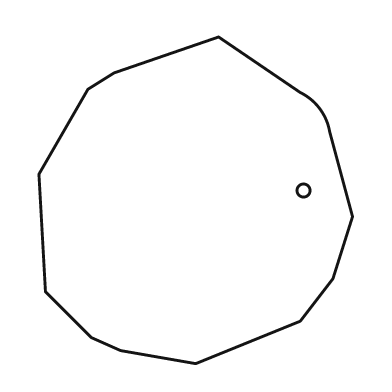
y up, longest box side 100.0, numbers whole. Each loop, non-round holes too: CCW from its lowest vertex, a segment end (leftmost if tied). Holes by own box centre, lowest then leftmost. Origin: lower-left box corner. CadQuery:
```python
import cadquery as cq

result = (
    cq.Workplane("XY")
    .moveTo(48.0, 0.0)
    .lineTo(80.0, 13.0)
    .lineTo(90.0, 26.0)
    .lineTo(96.0, 45.0)
    .lineTo(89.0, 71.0)
    .threePointArc((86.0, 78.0), (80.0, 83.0))
    .lineTo(55.0, 100.0)
    .lineTo(23.0, 89.0)
    .lineTo(15.0, 84.0)
    .lineTo(0.0, 58.0)
    .lineTo(2.0, 22.0)
    .lineTo(16.0, 8.0)
    .lineTo(25.0, 4.0)
    .close()
    .moveTo(81.0, 53.0)
    .circle(2.0)
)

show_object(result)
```